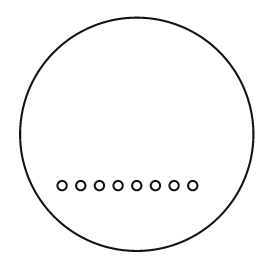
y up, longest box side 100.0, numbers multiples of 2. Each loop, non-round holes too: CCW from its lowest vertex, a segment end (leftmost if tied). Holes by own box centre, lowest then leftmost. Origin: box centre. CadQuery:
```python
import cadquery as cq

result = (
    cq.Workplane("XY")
    .moveTo(0.0, 0.0)
    .circle(50.0)
    .moveTo(-32.0, -22.0)
    .circle(2.0)
    .moveTo(-24.0, -22.0)
    .circle(2.0)
    .moveTo(-16.0, -22.0)
    .circle(2.0)
    .moveTo(-8.0, -22.0)
    .circle(2.0)
    .moveTo(0.0, -22.0)
    .circle(2.0)
    .moveTo(8.0, -22.0)
    .circle(2.0)
    .moveTo(16.0, -22.0)
    .circle(2.0)
    .moveTo(24.0, -22.0)
    .circle(2.0)
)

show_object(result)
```